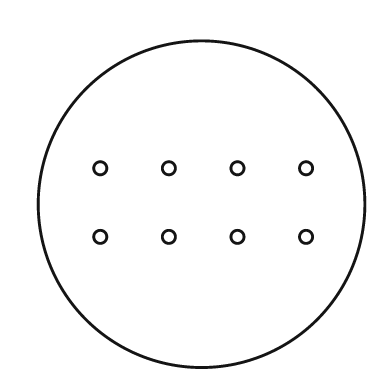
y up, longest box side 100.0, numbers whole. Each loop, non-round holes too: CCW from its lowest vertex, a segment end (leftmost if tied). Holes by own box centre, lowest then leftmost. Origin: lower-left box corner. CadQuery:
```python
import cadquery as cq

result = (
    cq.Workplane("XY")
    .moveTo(50.0, 50.0)
    .circle(50.0)
    .moveTo(19.0, 40.0)
    .circle(2.0)
    .moveTo(40.0, 40.0)
    .circle(2.0)
    .moveTo(61.0, 40.0)
    .circle(2.0)
    .moveTo(82.0, 40.0)
    .circle(2.0)
    .moveTo(19.0, 61.0)
    .circle(2.0)
    .moveTo(40.0, 61.0)
    .circle(2.0)
    .moveTo(61.0, 61.0)
    .circle(2.0)
    .moveTo(82.0, 61.0)
    .circle(2.0)
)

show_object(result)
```